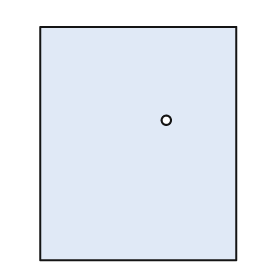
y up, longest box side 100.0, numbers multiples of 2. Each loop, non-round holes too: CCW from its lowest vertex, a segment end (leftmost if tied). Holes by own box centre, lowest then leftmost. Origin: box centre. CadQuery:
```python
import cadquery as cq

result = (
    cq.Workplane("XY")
    .moveTo(-42.0, -50.0)
    .lineTo(42.0, -50.0)
    .lineTo(42.0, 50.0)
    .lineTo(-42.0, 50.0)
    .close()
    .moveTo(12.0, 10.0)
    .circle(2.0)
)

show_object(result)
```